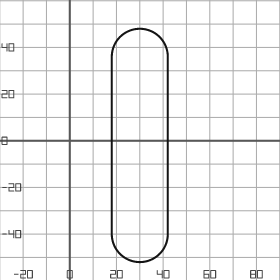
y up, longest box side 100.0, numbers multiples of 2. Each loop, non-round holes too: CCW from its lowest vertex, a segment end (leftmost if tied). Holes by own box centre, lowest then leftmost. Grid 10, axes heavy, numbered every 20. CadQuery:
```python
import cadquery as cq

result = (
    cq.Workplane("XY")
    .moveTo(18.0, -40.0)
    .threePointArc((30.0, -52.0), (42.0, -40.0))
    .lineTo(42.0, 36.0)
    .threePointArc((30.0, 48.0), (18.0, 36.0))
    .close()
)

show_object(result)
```